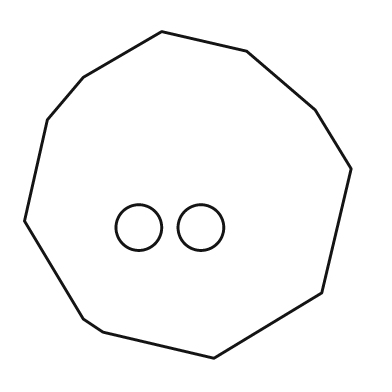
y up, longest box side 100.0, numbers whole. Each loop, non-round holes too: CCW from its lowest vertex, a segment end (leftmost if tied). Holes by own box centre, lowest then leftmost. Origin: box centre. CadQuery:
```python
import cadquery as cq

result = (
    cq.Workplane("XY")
    .moveTo(8.0, -50.0)
    .lineTo(41.0, -30.0)
    .lineTo(50.0, 8.0)
    .lineTo(39.0, 26.0)
    .lineTo(18.0, 44.0)
    .lineTo(-8.0, 50.0)
    .lineTo(-32.0, 36.0)
    .lineTo(-43.0, 23.0)
    .lineTo(-50.0, -8.0)
    .lineTo(-32.0, -38.0)
    .lineTo(-26.0, -42.0)
    .close()
    .moveTo(-15.0, -10.0)
    .circle(7.0)
    .moveTo(4.0, -10.0)
    .circle(7.0)
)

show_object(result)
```